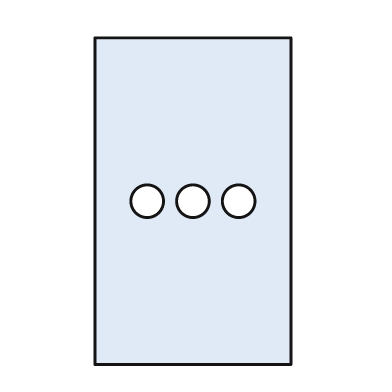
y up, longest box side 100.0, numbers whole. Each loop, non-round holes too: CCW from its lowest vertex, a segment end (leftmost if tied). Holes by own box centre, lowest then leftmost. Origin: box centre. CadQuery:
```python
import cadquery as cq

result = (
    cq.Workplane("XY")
    .moveTo(-30.0, -50.0)
    .lineTo(30.0, -50.0)
    .lineTo(30.0, 50.0)
    .lineTo(-30.0, 50.0)
    .close()
    .moveTo(-14.0, 0.0)
    .circle(5.0)
    .moveTo(0.0, 0.0)
    .circle(5.0)
    .moveTo(14.0, 0.0)
    .circle(5.0)
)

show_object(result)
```